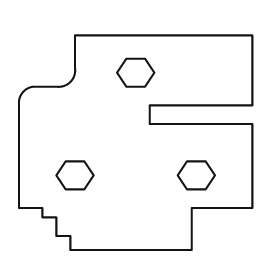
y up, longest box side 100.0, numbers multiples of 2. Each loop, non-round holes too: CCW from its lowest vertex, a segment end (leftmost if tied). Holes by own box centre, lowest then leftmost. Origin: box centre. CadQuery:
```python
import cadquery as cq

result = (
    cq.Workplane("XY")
    .moveTo(-28.0, -46.0)
    .lineTo(24.0, -46.0)
    .lineTo(24.0, -28.0)
    .lineTo(50.0, -28.0)
    .lineTo(50.0, 8.0)
    .lineTo(6.0, 8.0)
    .lineTo(6.0, 16.0)
    .lineTo(50.0, 16.0)
    .lineTo(50.0, 46.0)
    .lineTo(-26.0, 46.0)
    .lineTo(-26.0, 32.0)
    .threePointArc((-28.0, 26.0), (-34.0, 24.0))
    .lineTo(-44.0, 24.0)
    .threePointArc((-48.0, 22.0), (-50.0, 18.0))
    .lineTo(-50.0, -28.0)
    .lineTo(-40.0, -28.0)
    .lineTo(-40.0, -32.0)
    .lineTo(-34.0, -32.0)
    .lineTo(-34.0, -40.0)
    .lineTo(-28.0, -40.0)
    .close()
    .moveTo(-30.0, -20.0)
    .lineTo(-22.0, -20.0)
    .lineTo(-18.0, -14.0)
    .lineTo(-22.0, -8.0)
    .lineTo(-30.0, -8.0)
    .lineTo(-34.0, -14.0)
    .close()
    .moveTo(22.0, -20.0)
    .lineTo(30.0, -20.0)
    .lineTo(34.0, -14.0)
    .lineTo(30.0, -8.0)
    .lineTo(22.0, -8.0)
    .lineTo(18.0, -14.0)
    .close()
    .moveTo(-4.0, 24.0)
    .lineTo(4.0, 24.0)
    .lineTo(8.0, 30.0)
    .lineTo(4.0, 36.0)
    .lineTo(-4.0, 36.0)
    .lineTo(-8.0, 30.0)
    .close()
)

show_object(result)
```